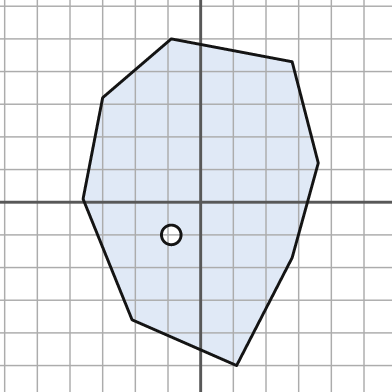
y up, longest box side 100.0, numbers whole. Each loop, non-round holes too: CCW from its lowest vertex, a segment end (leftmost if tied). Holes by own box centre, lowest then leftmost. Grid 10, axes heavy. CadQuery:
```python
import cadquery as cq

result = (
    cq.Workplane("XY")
    .moveTo(11.0, -50.0)
    .lineTo(28.0, -17.0)
    .lineTo(36.0, 12.0)
    .lineTo(28.0, 43.0)
    .lineTo(-9.0, 50.0)
    .lineTo(-30.0, 32.0)
    .lineTo(-36.0, 1.0)
    .lineTo(-21.0, -36.0)
    .close()
    .moveTo(-9.0, -10.0)
    .circle(3.0)
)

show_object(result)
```